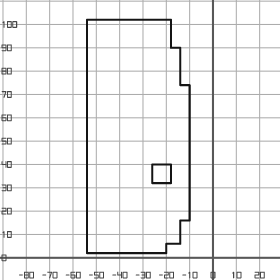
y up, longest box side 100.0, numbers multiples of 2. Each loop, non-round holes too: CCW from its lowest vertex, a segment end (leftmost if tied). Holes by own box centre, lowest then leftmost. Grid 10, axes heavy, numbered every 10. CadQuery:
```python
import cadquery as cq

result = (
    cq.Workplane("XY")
    .moveTo(-54.0, 2.0)
    .lineTo(-20.0, 2.0)
    .lineTo(-20.0, 6.0)
    .lineTo(-14.0, 6.0)
    .lineTo(-14.0, 16.0)
    .lineTo(-10.0, 16.0)
    .lineTo(-10.0, 74.0)
    .lineTo(-14.0, 74.0)
    .lineTo(-14.0, 90.0)
    .lineTo(-18.0, 90.0)
    .lineTo(-18.0, 102.0)
    .lineTo(-54.0, 102.0)
    .close()
    .moveTo(-26.0, 32.0)
    .lineTo(-18.0, 32.0)
    .lineTo(-18.0, 40.0)
    .lineTo(-26.0, 40.0)
    .close()
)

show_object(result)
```